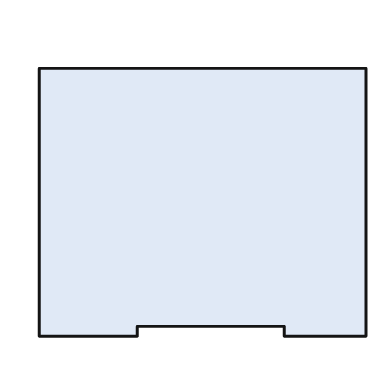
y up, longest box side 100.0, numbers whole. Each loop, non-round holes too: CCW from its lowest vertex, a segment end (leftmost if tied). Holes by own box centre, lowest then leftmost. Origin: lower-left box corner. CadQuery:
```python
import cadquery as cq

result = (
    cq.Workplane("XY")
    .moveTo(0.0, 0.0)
    .lineTo(30.0, 0.0)
    .lineTo(30.0, 3.0)
    .lineTo(75.0, 3.0)
    .lineTo(75.0, 0.0)
    .lineTo(100.0, 0.0)
    .lineTo(100.0, 82.0)
    .lineTo(0.0, 82.0)
    .close()
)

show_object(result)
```